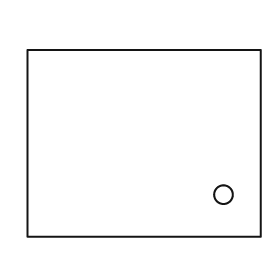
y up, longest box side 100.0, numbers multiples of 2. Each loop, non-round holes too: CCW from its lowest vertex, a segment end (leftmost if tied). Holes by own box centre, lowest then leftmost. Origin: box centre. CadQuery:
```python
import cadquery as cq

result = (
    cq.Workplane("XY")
    .moveTo(-50.0, -40.0)
    .lineTo(50.0, -40.0)
    .lineTo(50.0, 40.0)
    .lineTo(-50.0, 40.0)
    .close()
    .moveTo(34.0, -22.0)
    .circle(4.0)
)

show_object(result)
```